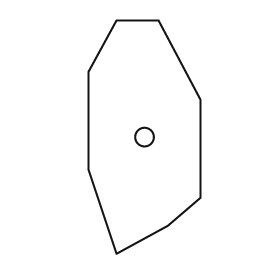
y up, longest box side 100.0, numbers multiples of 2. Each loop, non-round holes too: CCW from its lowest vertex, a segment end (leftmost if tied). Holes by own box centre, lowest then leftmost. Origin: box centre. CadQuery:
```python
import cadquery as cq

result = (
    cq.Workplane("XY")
    .moveTo(-12.0, -50.0)
    .lineTo(10.0, -38.0)
    .lineTo(24.0, -26.0)
    .lineTo(24.0, 16.0)
    .lineTo(6.0, 50.0)
    .lineTo(-12.0, 50.0)
    .lineTo(-24.0, 28.0)
    .lineTo(-24.0, -14.0)
    .close()
    .moveTo(0.0, 0.0)
    .circle(4.0)
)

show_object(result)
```